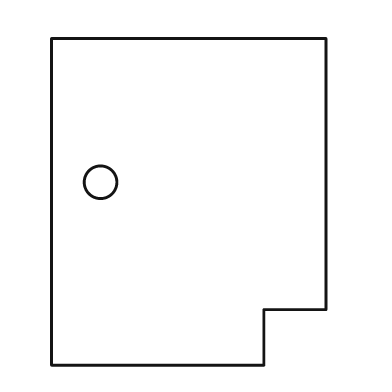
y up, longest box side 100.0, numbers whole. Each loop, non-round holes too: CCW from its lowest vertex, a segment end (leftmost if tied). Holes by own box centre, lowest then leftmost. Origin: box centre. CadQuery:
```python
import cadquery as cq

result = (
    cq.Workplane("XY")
    .moveTo(-42.0, -50.0)
    .lineTo(23.0, -50.0)
    .lineTo(23.0, -33.0)
    .lineTo(42.0, -33.0)
    .lineTo(42.0, 50.0)
    .lineTo(-42.0, 50.0)
    .close()
    .moveTo(-27.0, 6.0)
    .circle(5.0)
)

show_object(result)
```